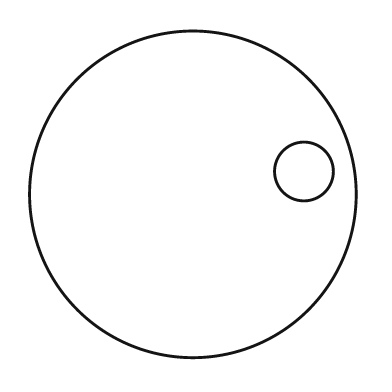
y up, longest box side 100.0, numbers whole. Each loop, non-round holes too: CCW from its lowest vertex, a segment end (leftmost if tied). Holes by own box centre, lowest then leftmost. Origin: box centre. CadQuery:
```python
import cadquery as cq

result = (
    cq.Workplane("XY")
    .moveTo(0.0, 0.0)
    .circle(50.0)
    .moveTo(34.0, 7.0)
    .circle(9.0)
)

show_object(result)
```